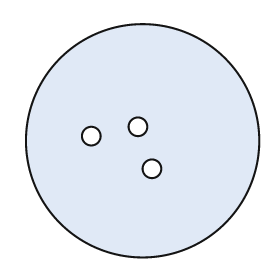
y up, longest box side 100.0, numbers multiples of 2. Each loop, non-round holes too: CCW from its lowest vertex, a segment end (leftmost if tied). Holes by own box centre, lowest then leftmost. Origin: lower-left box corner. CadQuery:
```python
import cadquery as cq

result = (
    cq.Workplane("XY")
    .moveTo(50.0, 50.0)
    .circle(50.0)
    .moveTo(54.0, 38.0)
    .circle(4.0)
    .moveTo(28.0, 52.0)
    .circle(4.0)
    .moveTo(48.0, 56.0)
    .circle(4.0)
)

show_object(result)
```